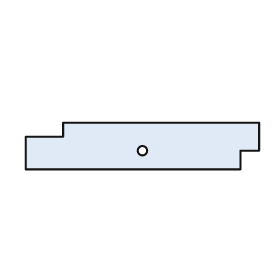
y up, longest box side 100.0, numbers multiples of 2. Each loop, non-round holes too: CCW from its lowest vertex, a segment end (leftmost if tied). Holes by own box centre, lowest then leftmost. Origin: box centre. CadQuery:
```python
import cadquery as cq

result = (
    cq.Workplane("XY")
    .moveTo(-50.0, -10.0)
    .lineTo(42.0, -10.0)
    .lineTo(42.0, -2.0)
    .lineTo(50.0, -2.0)
    .lineTo(50.0, 10.0)
    .lineTo(-34.0, 10.0)
    .lineTo(-34.0, 4.0)
    .lineTo(-50.0, 4.0)
    .close()
    .moveTo(0.0, -2.0)
    .circle(2.0)
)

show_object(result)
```